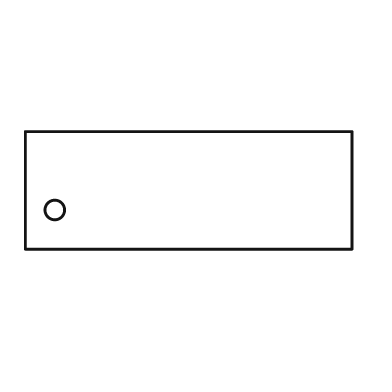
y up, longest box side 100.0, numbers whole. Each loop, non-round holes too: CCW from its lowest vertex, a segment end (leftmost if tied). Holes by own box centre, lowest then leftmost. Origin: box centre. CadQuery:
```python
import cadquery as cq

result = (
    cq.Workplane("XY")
    .moveTo(-50.0, -18.0)
    .lineTo(50.0, -18.0)
    .lineTo(50.0, 18.0)
    .lineTo(-50.0, 18.0)
    .close()
    .moveTo(-41.0, -6.0)
    .circle(3.0)
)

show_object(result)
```